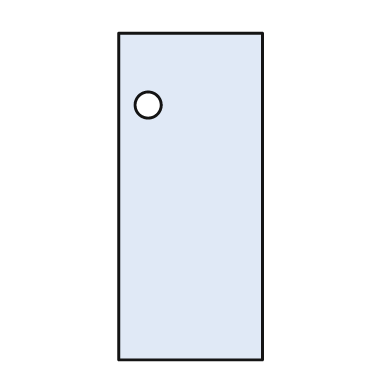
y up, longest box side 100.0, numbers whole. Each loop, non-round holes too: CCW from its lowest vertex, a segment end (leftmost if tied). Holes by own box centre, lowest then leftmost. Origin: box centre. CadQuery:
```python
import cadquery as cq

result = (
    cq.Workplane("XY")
    .moveTo(-22.0, -50.0)
    .lineTo(22.0, -50.0)
    .lineTo(22.0, 50.0)
    .lineTo(-22.0, 50.0)
    .close()
    .moveTo(-13.0, 28.0)
    .circle(4.0)
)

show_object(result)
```